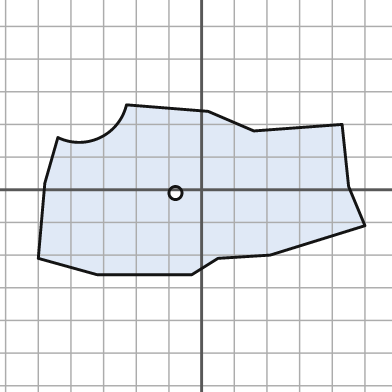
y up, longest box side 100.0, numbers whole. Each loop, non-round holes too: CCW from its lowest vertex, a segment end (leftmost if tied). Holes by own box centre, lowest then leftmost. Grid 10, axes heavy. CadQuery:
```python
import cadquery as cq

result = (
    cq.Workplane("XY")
    .moveTo(-32.0, -26.0)
    .lineTo(-3.0, -26.0)
    .lineTo(5.0, -21.0)
    .lineTo(21.0, -20.0)
    .lineTo(50.0, -11.0)
    .lineTo(45.0, 1.0)
    .lineTo(43.0, 20.0)
    .lineTo(16.0, 18.0)
    .lineTo(2.0, 24.0)
    .lineTo(-23.0, 26.0)
    .threePointArc((-31.0, 16.0), (-44.0, 16.0))
    .lineTo(-48.0, 2.0)
    .lineTo(-50.0, -21.0)
    .close()
    .moveTo(-8.0, -1.0)
    .circle(2.0)
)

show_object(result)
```